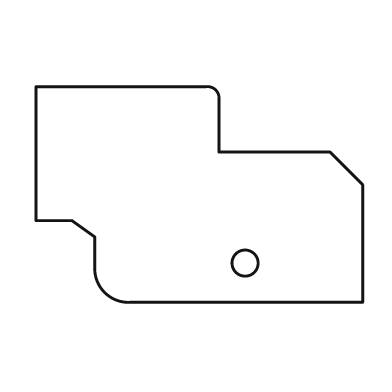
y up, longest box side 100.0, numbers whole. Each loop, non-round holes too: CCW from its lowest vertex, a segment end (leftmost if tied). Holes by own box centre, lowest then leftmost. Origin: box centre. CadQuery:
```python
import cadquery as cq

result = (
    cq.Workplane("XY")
    .moveTo(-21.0, -33.0)
    .lineTo(50.0, -33.0)
    .lineTo(50.0, 3.0)
    .lineTo(40.0, 13.0)
    .lineTo(6.0, 13.0)
    .lineTo(6.0, 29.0)
    .threePointArc((5.0, 32.0), (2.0, 33.0))
    .lineTo(-50.0, 33.0)
    .lineTo(-50.0, -8.0)
    .lineTo(-39.0, -8.0)
    .lineTo(-32.0, -13.0)
    .lineTo(-32.0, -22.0)
    .threePointArc((-29.0, -30.0), (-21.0, -33.0))
    .close()
    .moveTo(14.0, -21.0)
    .circle(4.0)
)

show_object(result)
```